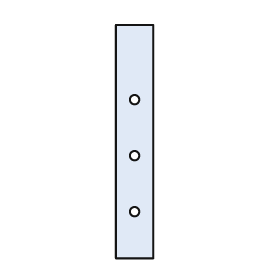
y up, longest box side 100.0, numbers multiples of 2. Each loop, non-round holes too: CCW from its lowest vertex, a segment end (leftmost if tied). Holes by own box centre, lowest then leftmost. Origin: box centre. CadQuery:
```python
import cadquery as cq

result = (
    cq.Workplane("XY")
    .moveTo(-8.0, -50.0)
    .lineTo(8.0, -50.0)
    .lineTo(8.0, 50.0)
    .lineTo(-8.0, 50.0)
    .close()
    .moveTo(0.0, -30.0)
    .circle(2.0)
    .moveTo(0.0, -6.0)
    .circle(2.0)
    .moveTo(0.0, 18.0)
    .circle(2.0)
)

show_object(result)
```